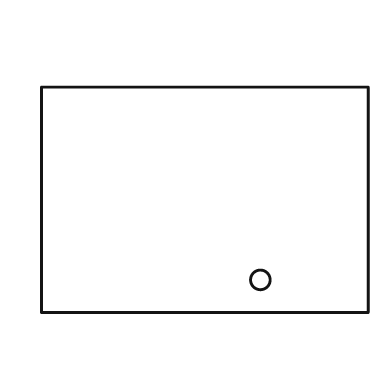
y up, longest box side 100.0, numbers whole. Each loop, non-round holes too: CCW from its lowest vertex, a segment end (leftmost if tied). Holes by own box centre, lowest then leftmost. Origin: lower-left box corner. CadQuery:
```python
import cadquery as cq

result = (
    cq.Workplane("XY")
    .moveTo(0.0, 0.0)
    .lineTo(100.0, 0.0)
    .lineTo(100.0, 69.0)
    .lineTo(0.0, 69.0)
    .close()
    .moveTo(67.0, 10.0)
    .circle(3.0)
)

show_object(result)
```